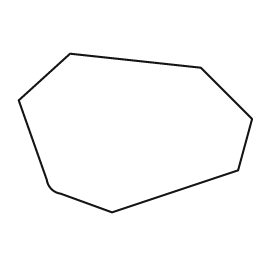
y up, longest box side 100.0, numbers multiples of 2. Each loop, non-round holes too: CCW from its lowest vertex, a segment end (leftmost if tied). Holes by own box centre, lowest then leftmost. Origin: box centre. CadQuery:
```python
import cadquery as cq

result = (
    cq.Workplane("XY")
    .moveTo(-10.0, -34.0)
    .lineTo(44.0, -16.0)
    .lineTo(50.0, 6.0)
    .lineTo(28.0, 28.0)
    .lineTo(-28.0, 34.0)
    .lineTo(-50.0, 14.0)
    .lineTo(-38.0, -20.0)
    .threePointArc((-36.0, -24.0), (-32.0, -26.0))
    .close()
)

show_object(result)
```